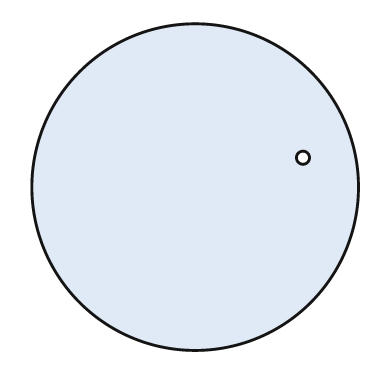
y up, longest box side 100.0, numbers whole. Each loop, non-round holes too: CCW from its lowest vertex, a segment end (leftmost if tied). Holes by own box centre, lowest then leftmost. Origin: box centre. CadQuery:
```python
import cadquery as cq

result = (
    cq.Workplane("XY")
    .moveTo(0.0, 0.0)
    .circle(50.0)
    .moveTo(33.0, 9.0)
    .circle(2.0)
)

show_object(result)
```